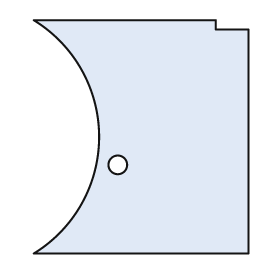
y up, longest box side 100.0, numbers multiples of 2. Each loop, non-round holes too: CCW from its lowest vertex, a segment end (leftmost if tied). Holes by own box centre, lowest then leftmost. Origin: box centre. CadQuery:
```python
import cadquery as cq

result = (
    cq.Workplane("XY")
    .moveTo(-46.0, -50.0)
    .lineTo(46.0, -50.0)
    .lineTo(46.0, 46.0)
    .lineTo(32.0, 46.0)
    .lineTo(32.0, 50.0)
    .lineTo(-46.0, 50.0)
    .threePointArc((-18.0, 0.0), (-46.0, -50.0))
    .close()
    .moveTo(-10.0, -12.0)
    .circle(4.0)
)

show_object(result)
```